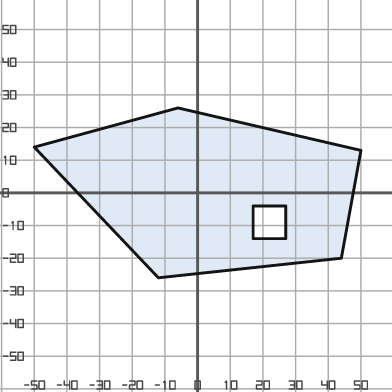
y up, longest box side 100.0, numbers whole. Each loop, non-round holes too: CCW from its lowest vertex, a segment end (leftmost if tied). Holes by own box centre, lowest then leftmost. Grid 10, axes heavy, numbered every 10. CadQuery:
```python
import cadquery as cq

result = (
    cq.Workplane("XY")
    .moveTo(-12.0, -26.0)
    .lineTo(44.0, -20.0)
    .lineTo(50.0, 13.0)
    .lineTo(-6.0, 26.0)
    .lineTo(-50.0, 14.0)
    .close()
    .moveTo(17.0, -14.0)
    .lineTo(27.0, -14.0)
    .lineTo(27.0, -4.0)
    .lineTo(17.0, -4.0)
    .close()
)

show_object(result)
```